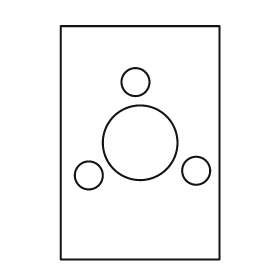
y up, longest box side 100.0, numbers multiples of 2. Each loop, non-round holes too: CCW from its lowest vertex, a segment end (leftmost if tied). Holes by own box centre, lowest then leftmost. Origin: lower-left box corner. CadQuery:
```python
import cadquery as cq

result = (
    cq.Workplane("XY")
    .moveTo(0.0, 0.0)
    .lineTo(68.0, 0.0)
    .lineTo(68.0, 100.0)
    .lineTo(0.0, 100.0)
    .close()
    .moveTo(12.0, 36.0)
    .circle(6.0)
    .moveTo(58.0, 38.0)
    .circle(6.0)
    .moveTo(34.0, 50.0)
    .circle(16.0)
    .moveTo(32.0, 76.0)
    .circle(6.0)
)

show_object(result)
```